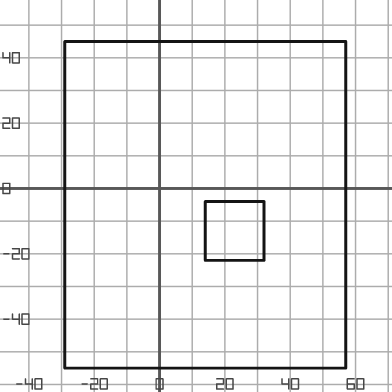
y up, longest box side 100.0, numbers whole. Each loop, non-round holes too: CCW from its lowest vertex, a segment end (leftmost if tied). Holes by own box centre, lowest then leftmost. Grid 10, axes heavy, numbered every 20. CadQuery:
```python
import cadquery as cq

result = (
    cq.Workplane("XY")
    .moveTo(-29.0, -55.0)
    .lineTo(57.0, -55.0)
    .lineTo(57.0, 45.0)
    .lineTo(-29.0, 45.0)
    .close()
    .moveTo(14.0, -22.0)
    .lineTo(32.0, -22.0)
    .lineTo(32.0, -4.0)
    .lineTo(14.0, -4.0)
    .close()
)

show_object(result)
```